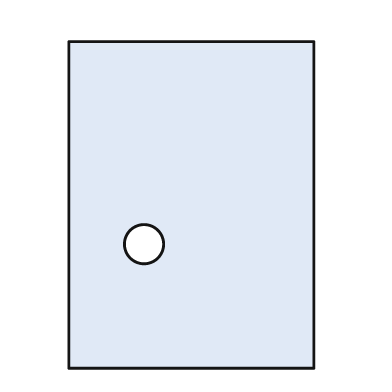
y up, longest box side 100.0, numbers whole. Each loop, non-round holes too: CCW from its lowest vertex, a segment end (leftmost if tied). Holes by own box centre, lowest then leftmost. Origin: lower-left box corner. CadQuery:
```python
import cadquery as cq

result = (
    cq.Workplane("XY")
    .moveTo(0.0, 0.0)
    .lineTo(75.0, 0.0)
    .lineTo(75.0, 100.0)
    .lineTo(0.0, 100.0)
    .close()
    .moveTo(23.0, 38.0)
    .circle(6.0)
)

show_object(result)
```